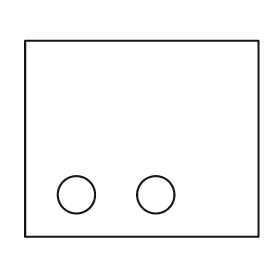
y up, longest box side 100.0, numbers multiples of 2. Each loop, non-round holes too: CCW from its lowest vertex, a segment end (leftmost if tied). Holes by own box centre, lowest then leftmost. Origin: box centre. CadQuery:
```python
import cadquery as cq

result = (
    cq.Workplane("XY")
    .moveTo(-50.0, -42.0)
    .lineTo(50.0, -42.0)
    .lineTo(50.0, 42.0)
    .lineTo(-50.0, 42.0)
    .close()
    .moveTo(-28.0, -24.0)
    .circle(8.0)
    .moveTo(6.0, -24.0)
    .circle(8.0)
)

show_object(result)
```